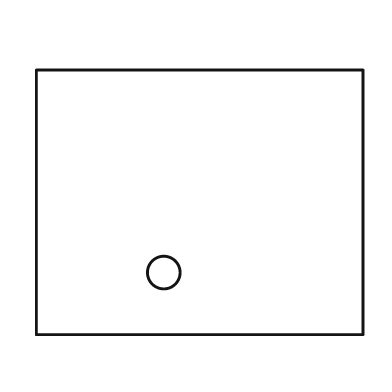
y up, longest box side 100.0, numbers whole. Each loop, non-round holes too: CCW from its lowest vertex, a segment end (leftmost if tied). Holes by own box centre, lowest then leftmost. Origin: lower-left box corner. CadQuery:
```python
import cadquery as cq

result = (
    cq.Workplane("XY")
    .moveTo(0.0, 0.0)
    .lineTo(100.0, 0.0)
    .lineTo(100.0, 81.0)
    .lineTo(0.0, 81.0)
    .close()
    .moveTo(39.0, 19.0)
    .circle(5.0)
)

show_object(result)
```